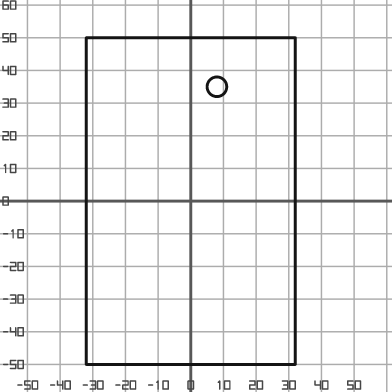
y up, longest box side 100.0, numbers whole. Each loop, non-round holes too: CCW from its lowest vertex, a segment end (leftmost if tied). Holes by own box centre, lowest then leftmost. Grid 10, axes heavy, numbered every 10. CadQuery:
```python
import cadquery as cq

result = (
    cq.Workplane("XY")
    .moveTo(-32.0, -50.0)
    .lineTo(32.0, -50.0)
    .lineTo(32.0, 50.0)
    .lineTo(-32.0, 50.0)
    .close()
    .moveTo(8.0, 35.0)
    .circle(3.0)
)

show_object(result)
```